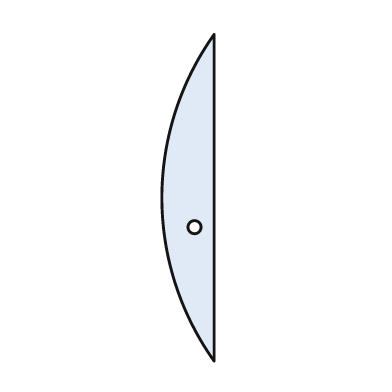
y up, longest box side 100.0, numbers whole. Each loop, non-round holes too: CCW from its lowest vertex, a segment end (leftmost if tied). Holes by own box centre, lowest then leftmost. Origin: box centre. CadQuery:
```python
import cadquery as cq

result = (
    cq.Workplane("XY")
    .moveTo(8.0, -50.0)
    .lineTo(8.0, 50.0)
    .threePointArc((-8.0, 0.0), (8.0, -50.0))
    .close()
    .moveTo(2.0, -9.0)
    .circle(2.0)
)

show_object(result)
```